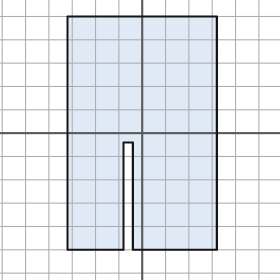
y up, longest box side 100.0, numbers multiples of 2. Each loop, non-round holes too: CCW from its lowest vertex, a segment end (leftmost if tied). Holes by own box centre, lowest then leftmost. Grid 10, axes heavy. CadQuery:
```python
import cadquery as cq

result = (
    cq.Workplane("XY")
    .moveTo(-32.0, -50.0)
    .lineTo(-8.0, -50.0)
    .lineTo(-8.0, -4.0)
    .lineTo(-4.0, -4.0)
    .lineTo(-4.0, -50.0)
    .lineTo(32.0, -50.0)
    .lineTo(32.0, 50.0)
    .lineTo(-32.0, 50.0)
    .close()
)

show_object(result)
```